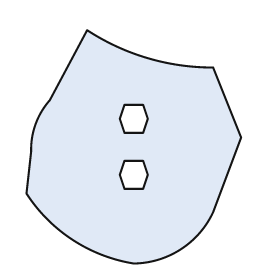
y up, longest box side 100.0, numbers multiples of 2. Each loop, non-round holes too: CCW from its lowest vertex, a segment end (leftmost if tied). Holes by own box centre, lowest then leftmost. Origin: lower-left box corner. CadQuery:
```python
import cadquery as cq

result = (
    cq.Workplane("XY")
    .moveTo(46.0, 0.0)
    .threePointArc((66.0, 6.0), (80.0, 22.0))
    .lineTo(92.0, 54.0)
    .lineTo(80.0, 84.0)
    .threePointArc((52.0, 88.0), (26.0, 100.0))
    .lineTo(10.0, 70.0)
    .threePointArc((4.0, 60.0), (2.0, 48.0))
    .lineTo(0.0, 30.0)
    .threePointArc((20.0, 10.0), (46.0, 0.0))
    .close()
    .moveTo(42.0, 32.0)
    .lineTo(50.0, 32.0)
    .lineTo(52.0, 38.0)
    .lineTo(50.0, 44.0)
    .lineTo(42.0, 44.0)
    .lineTo(40.0, 38.0)
    .close()
    .moveTo(42.0, 56.0)
    .lineTo(50.0, 56.0)
    .lineTo(52.0, 62.0)
    .lineTo(50.0, 68.0)
    .lineTo(42.0, 68.0)
    .lineTo(40.0, 62.0)
    .close()
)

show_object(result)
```